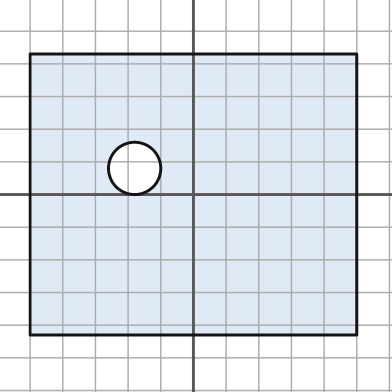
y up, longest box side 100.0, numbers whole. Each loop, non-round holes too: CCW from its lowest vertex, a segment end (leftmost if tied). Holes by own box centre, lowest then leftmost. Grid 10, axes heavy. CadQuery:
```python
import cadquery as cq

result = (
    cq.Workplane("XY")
    .moveTo(-50.0, -43.0)
    .lineTo(50.0, -43.0)
    .lineTo(50.0, 43.0)
    .lineTo(-50.0, 43.0)
    .close()
    .moveTo(-18.0, 8.0)
    .circle(8.0)
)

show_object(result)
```